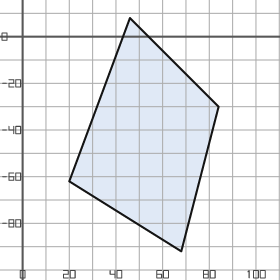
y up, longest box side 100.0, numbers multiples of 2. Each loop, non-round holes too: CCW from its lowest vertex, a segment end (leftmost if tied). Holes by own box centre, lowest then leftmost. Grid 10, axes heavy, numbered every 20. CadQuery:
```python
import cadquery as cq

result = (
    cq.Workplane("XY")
    .moveTo(68.0, -92.0)
    .lineTo(84.0, -30.0)
    .lineTo(46.0, 8.0)
    .lineTo(20.0, -62.0)
    .close()
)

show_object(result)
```